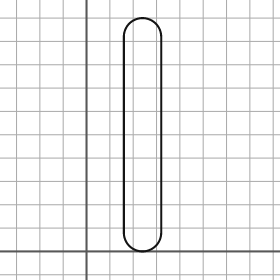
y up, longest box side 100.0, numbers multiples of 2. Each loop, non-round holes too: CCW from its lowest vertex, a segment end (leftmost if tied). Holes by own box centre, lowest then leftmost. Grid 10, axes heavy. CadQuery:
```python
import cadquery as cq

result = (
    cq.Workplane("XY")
    .moveTo(16.0, 8.0)
    .threePointArc((24.0, 0.0), (32.0, 8.0))
    .lineTo(32.0, 92.0)
    .threePointArc((24.0, 100.0), (16.0, 92.0))
    .close()
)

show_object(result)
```